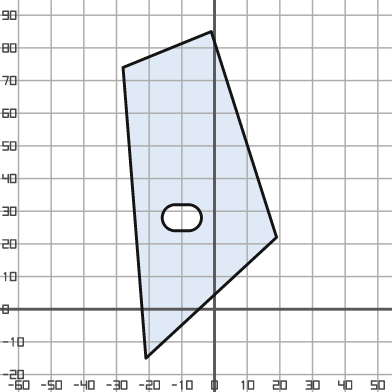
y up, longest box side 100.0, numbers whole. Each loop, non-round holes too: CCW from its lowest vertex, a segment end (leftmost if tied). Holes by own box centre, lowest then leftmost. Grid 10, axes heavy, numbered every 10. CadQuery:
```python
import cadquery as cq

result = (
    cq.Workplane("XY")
    .moveTo(-21.0, -15.0)
    .lineTo(19.0, 22.0)
    .lineTo(-1.0, 85.0)
    .lineTo(-28.0, 74.0)
    .close()
    .moveTo(-12.0, 24.0)
    .lineTo(-8.0, 24.0)
    .threePointArc((-4.0, 28.0), (-8.0, 32.0))
    .lineTo(-12.0, 32.0)
    .threePointArc((-16.0, 28.0), (-12.0, 24.0))
    .close()
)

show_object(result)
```